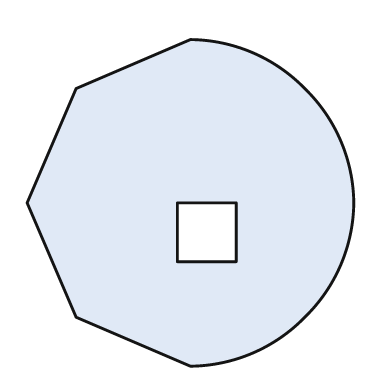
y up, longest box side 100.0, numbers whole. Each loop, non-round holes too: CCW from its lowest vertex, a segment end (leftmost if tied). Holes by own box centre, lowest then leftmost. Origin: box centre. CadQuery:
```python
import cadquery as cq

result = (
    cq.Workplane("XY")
    .moveTo(0.0, -50.0)
    .threePointArc((19.0, -46.0), (35.0, -35.0))
    .threePointArc((46.0, -19.0), (50.0, 0.0))
    .threePointArc((46.0, 19.0), (35.0, 35.0))
    .threePointArc((19.0, 46.0), (0.0, 50.0))
    .lineTo(-35.0, 35.0)
    .lineTo(-50.0, 0.0)
    .lineTo(-35.0, -35.0)
    .close()
    .moveTo(-4.0, -18.0)
    .lineTo(14.0, -18.0)
    .lineTo(14.0, 0.0)
    .lineTo(-4.0, 0.0)
    .close()
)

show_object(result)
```